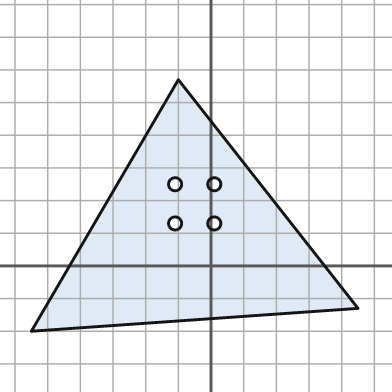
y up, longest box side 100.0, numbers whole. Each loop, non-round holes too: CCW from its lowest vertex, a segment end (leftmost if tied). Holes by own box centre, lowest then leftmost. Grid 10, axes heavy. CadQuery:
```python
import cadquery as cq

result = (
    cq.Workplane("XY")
    .moveTo(-55.0, -20.0)
    .lineTo(45.0, -13.0)
    .lineTo(-10.0, 57.0)
    .close()
    .moveTo(-11.0, 13.0)
    .circle(2.0)
    .moveTo(1.0, 13.0)
    .circle(2.0)
    .moveTo(-11.0, 25.0)
    .circle(2.0)
    .moveTo(1.0, 25.0)
    .circle(2.0)
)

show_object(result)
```